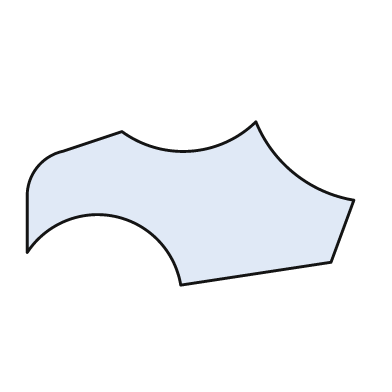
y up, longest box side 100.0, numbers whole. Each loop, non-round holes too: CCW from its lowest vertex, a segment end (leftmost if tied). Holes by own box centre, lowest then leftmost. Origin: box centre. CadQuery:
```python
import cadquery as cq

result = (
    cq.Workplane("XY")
    .moveTo(-3.0, -25.0)
    .lineTo(43.0, -18.0)
    .lineTo(50.0, 1.0)
    .threePointArc((32.0, 9.0), (20.0, 25.0))
    .threePointArc((0.0, 16.0), (-21.0, 22.0))
    .lineTo(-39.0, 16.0)
    .threePointArc((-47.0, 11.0), (-50.0, 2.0))
    .lineTo(-50.0, -15.0)
    .threePointArc((-23.0, -4.0), (-3.0, -25.0))
    .close()
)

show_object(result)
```